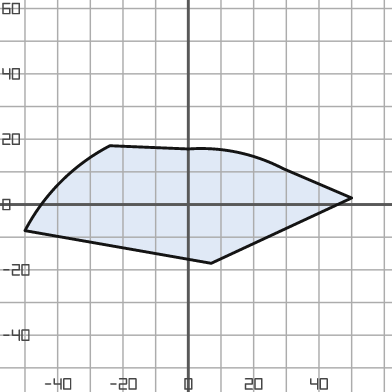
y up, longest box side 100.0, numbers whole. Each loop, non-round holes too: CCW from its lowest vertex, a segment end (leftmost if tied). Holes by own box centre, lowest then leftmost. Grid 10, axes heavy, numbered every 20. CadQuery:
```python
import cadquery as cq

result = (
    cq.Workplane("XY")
    .moveTo(7.0, -18.0)
    .lineTo(50.0, 2.0)
    .lineTo(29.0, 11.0)
    .threePointArc((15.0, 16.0), (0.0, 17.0))
    .lineTo(-24.0, 18.0)
    .threePointArc((-39.0, 7.0), (-50.0, -8.0))
    .close()
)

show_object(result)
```